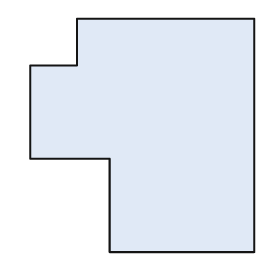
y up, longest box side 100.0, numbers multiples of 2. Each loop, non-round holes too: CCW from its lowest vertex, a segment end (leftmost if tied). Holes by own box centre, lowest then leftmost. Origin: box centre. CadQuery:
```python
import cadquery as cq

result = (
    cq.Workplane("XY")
    .moveTo(-14.0, -50.0)
    .lineTo(48.0, -50.0)
    .lineTo(48.0, 50.0)
    .lineTo(-28.0, 50.0)
    .lineTo(-28.0, 30.0)
    .lineTo(-48.0, 30.0)
    .lineTo(-48.0, -10.0)
    .lineTo(-14.0, -10.0)
    .close()
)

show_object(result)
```